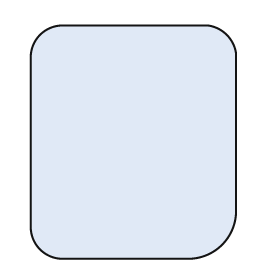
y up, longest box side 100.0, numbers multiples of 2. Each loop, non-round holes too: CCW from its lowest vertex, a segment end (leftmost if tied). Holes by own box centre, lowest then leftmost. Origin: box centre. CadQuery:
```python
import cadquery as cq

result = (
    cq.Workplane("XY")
    .moveTo(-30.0, -50.0)
    .lineTo(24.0, -50.0)
    .threePointArc((38.0, -44.0), (44.0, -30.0))
    .lineTo(44.0, 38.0)
    .threePointArc((40.0, 46.0), (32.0, 50.0))
    .lineTo(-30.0, 50.0)
    .threePointArc((-40.0, 46.0), (-44.0, 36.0))
    .lineTo(-44.0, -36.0)
    .threePointArc((-40.0, -46.0), (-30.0, -50.0))
    .close()
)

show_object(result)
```